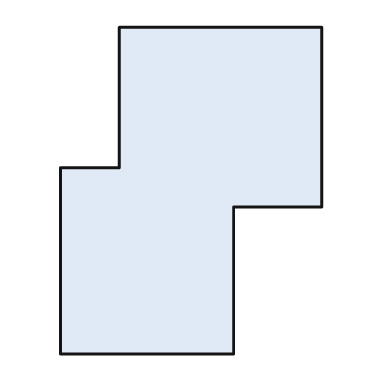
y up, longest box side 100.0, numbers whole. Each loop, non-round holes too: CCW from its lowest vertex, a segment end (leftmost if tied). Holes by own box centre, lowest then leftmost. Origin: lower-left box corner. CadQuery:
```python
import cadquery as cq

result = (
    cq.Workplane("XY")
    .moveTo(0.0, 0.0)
    .lineTo(53.0, 0.0)
    .lineTo(53.0, 45.0)
    .lineTo(80.0, 45.0)
    .lineTo(80.0, 100.0)
    .lineTo(18.0, 100.0)
    .lineTo(18.0, 57.0)
    .lineTo(0.0, 57.0)
    .close()
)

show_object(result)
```